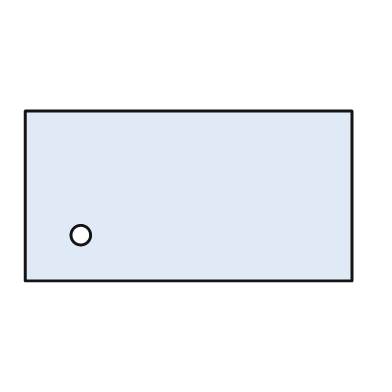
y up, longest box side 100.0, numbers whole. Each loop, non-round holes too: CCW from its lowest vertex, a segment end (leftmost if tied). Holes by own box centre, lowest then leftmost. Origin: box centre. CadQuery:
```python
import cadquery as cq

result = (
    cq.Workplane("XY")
    .moveTo(-50.0, -26.0)
    .lineTo(50.0, -26.0)
    .lineTo(50.0, 26.0)
    .lineTo(-50.0, 26.0)
    .close()
    .moveTo(-33.0, -12.0)
    .circle(3.0)
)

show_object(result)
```